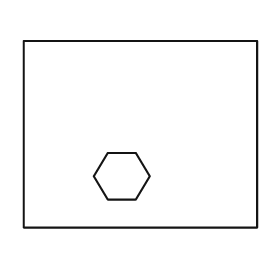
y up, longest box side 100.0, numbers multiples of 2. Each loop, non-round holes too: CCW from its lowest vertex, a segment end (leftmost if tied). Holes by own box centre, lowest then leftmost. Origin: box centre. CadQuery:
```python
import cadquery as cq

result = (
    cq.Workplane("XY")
    .moveTo(-50.0, -40.0)
    .lineTo(50.0, -40.0)
    .lineTo(50.0, 40.0)
    .lineTo(-50.0, 40.0)
    .close()
    .moveTo(-14.0, -28.0)
    .lineTo(-2.0, -28.0)
    .lineTo(4.0, -18.0)
    .lineTo(-2.0, -8.0)
    .lineTo(-14.0, -8.0)
    .lineTo(-20.0, -18.0)
    .close()
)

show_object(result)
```